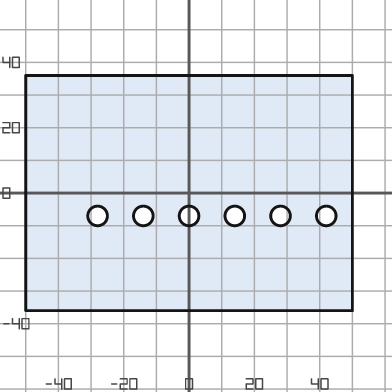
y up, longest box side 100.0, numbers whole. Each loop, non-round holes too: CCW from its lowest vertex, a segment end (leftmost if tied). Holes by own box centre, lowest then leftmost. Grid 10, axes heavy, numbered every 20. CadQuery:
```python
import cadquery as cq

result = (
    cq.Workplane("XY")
    .moveTo(-50.0, -36.0)
    .lineTo(50.0, -36.0)
    .lineTo(50.0, 36.0)
    .lineTo(-50.0, 36.0)
    .close()
    .moveTo(-28.0, -7.0)
    .circle(3.0)
    .moveTo(-14.0, -7.0)
    .circle(3.0)
    .moveTo(0.0, -7.0)
    .circle(3.0)
    .moveTo(14.0, -7.0)
    .circle(3.0)
    .moveTo(28.0, -7.0)
    .circle(3.0)
    .moveTo(42.0, -7.0)
    .circle(3.0)
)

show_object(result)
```